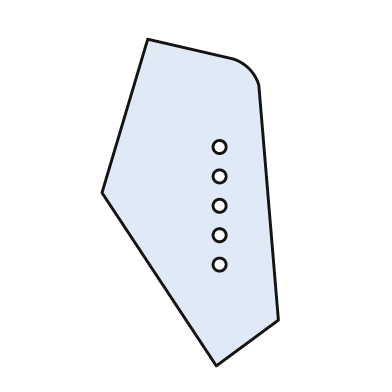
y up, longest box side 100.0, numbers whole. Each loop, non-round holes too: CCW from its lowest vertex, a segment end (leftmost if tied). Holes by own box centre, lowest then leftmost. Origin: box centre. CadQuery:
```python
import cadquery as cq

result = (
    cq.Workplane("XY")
    .moveTo(8.0, -50.0)
    .lineTo(27.0, -36.0)
    .lineTo(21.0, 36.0)
    .threePointArc((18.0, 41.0), (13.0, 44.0))
    .lineTo(-13.0, 50.0)
    .lineTo(-27.0, 3.0)
    .close()
    .moveTo(9.0, -19.0)
    .circle(2.0)
    .moveTo(9.0, -10.0)
    .circle(2.0)
    .moveTo(9.0, -1.0)
    .circle(2.0)
    .moveTo(9.0, 8.0)
    .circle(2.0)
    .moveTo(9.0, 17.0)
    .circle(2.0)
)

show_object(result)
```